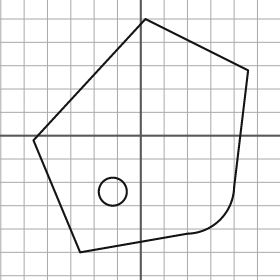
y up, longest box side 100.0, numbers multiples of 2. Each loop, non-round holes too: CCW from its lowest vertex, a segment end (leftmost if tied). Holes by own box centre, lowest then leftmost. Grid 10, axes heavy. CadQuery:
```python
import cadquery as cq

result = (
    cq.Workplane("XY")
    .moveTo(-26.0, -50.0)
    .lineTo(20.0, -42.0)
    .threePointArc((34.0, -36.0), (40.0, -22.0))
    .lineTo(46.0, 28.0)
    .lineTo(2.0, 50.0)
    .lineTo(-46.0, -2.0)
    .close()
    .moveTo(-12.0, -24.0)
    .circle(6.0)
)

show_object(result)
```